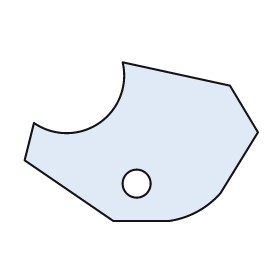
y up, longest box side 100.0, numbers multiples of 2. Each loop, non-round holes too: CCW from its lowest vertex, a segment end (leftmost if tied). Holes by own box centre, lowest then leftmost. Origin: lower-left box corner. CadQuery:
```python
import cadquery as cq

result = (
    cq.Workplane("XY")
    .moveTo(38.0, 0.0)
    .lineTo(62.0, 0.0)
    .threePointArc((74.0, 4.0), (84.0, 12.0))
    .lineTo(100.0, 38.0)
    .lineTo(88.0, 58.0)
    .lineTo(42.0, 68.0)
    .threePointArc((32.0, 42.0), (4.0, 42.0))
    .lineTo(0.0, 26.0)
    .close()
    .moveTo(48.0, 16.0)
    .circle(6.0)
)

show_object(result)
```